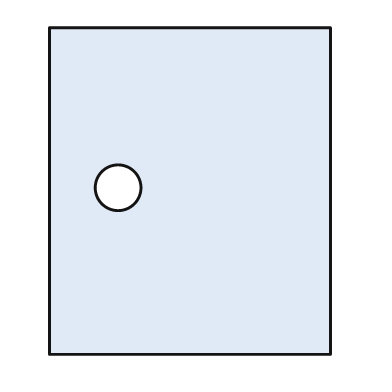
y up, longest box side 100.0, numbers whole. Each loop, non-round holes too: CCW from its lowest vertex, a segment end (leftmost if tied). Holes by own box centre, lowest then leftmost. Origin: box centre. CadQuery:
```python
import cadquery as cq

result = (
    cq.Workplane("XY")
    .moveTo(-43.0, -50.0)
    .lineTo(43.0, -50.0)
    .lineTo(43.0, 50.0)
    .lineTo(-43.0, 50.0)
    .close()
    .moveTo(-22.0, 1.0)
    .circle(7.0)
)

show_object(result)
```